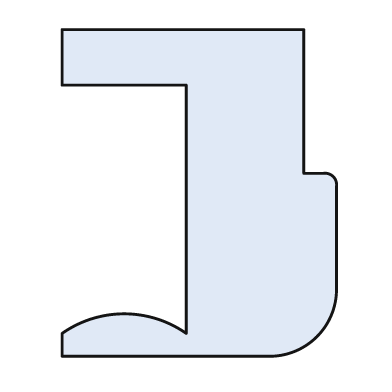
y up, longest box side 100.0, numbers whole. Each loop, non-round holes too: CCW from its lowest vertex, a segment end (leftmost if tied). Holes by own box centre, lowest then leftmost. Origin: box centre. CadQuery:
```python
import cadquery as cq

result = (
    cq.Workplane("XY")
    .moveTo(-42.0, -50.0)
    .lineTo(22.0, -50.0)
    .threePointArc((36.0, -44.0), (42.0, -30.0))
    .lineTo(42.0, 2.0)
    .threePointArc((41.0, 5.0), (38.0, 6.0))
    .lineTo(32.0, 6.0)
    .lineTo(32.0, 50.0)
    .lineTo(-42.0, 50.0)
    .lineTo(-42.0, 33.0)
    .lineTo(-4.0, 33.0)
    .lineTo(-4.0, -43.0)
    .threePointArc((-23.0, -37.0), (-42.0, -43.0))
    .close()
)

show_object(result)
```